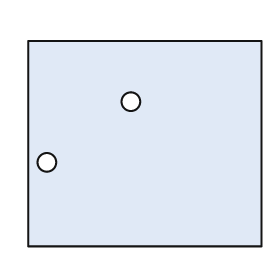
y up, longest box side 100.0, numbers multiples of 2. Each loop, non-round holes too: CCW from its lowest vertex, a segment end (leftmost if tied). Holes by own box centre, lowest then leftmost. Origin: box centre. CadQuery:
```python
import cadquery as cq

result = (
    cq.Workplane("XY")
    .moveTo(-50.0, -44.0)
    .lineTo(50.0, -44.0)
    .lineTo(50.0, 44.0)
    .lineTo(-50.0, 44.0)
    .close()
    .moveTo(-42.0, -8.0)
    .circle(4.0)
    .moveTo(-6.0, 18.0)
    .circle(4.0)
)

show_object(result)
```